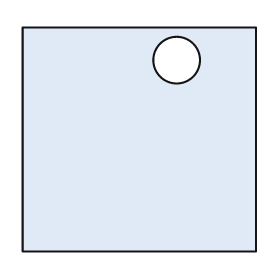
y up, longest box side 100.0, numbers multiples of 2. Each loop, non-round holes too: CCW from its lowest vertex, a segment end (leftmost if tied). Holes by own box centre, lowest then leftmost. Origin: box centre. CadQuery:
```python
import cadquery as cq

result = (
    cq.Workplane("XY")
    .moveTo(-50.0, -48.0)
    .lineTo(50.0, -48.0)
    .lineTo(50.0, 48.0)
    .lineTo(-50.0, 48.0)
    .close()
    .moveTo(16.0, 34.0)
    .circle(10.0)
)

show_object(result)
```